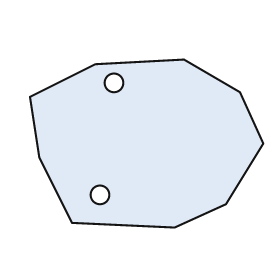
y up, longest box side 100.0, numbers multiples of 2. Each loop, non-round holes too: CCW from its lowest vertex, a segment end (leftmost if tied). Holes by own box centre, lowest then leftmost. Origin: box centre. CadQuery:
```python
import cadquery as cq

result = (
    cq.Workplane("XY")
    .moveTo(12.0, -36.0)
    .lineTo(34.0, -26.0)
    .lineTo(50.0, 0.0)
    .lineTo(40.0, 22.0)
    .lineTo(16.0, 36.0)
    .lineTo(-22.0, 34.0)
    .lineTo(-50.0, 20.0)
    .lineTo(-46.0, -6.0)
    .lineTo(-32.0, -34.0)
    .close()
    .moveTo(-20.0, -22.0)
    .circle(4.0)
    .moveTo(-14.0, 26.0)
    .circle(4.0)
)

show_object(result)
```